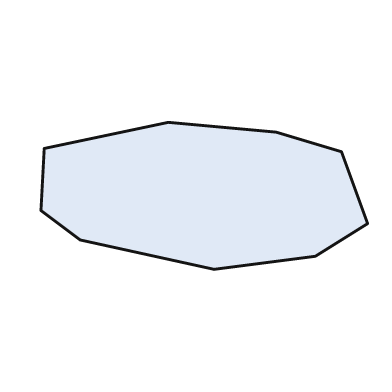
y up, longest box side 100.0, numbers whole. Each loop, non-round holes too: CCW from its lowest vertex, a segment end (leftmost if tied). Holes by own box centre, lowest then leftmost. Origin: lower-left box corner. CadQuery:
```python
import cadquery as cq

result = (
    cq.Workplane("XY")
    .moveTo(53.0, 0.0)
    .lineTo(84.0, 4.0)
    .lineTo(100.0, 14.0)
    .lineTo(92.0, 36.0)
    .lineTo(72.0, 42.0)
    .lineTo(39.0, 45.0)
    .lineTo(1.0, 37.0)
    .lineTo(0.0, 18.0)
    .lineTo(12.0, 9.0)
    .close()
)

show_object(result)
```